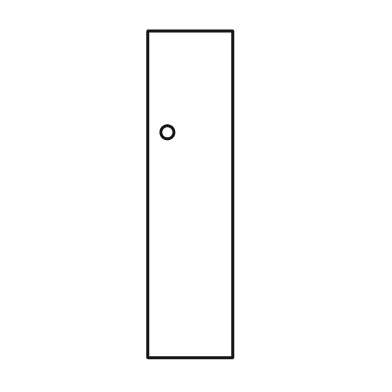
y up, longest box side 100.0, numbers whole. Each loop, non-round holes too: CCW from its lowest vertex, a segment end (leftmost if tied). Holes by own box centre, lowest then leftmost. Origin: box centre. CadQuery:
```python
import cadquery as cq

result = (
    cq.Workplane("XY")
    .moveTo(-13.0, -50.0)
    .lineTo(13.0, -50.0)
    .lineTo(13.0, 50.0)
    .lineTo(-13.0, 50.0)
    .close()
    .moveTo(-7.0, 19.0)
    .circle(2.0)
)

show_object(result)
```